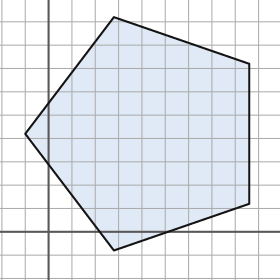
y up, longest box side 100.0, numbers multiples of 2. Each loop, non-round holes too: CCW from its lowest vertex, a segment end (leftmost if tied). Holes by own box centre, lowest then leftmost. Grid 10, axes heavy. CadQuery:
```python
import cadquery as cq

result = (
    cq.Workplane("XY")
    .moveTo(28.0, -8.0)
    .lineTo(86.0, 12.0)
    .lineTo(86.0, 72.0)
    .lineTo(28.0, 92.0)
    .lineTo(-10.0, 42.0)
    .close()
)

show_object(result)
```